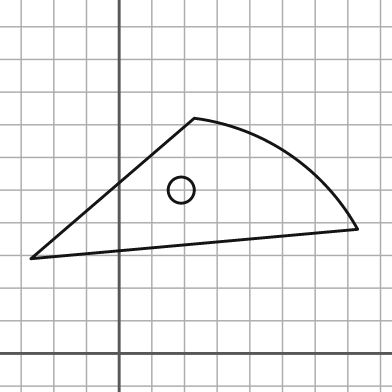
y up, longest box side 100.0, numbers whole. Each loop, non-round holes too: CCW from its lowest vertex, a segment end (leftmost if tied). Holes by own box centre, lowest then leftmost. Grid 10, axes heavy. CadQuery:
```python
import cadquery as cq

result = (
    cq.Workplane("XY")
    .moveTo(-27.0, 29.0)
    .lineTo(73.0, 38.0)
    .threePointArc((52.0, 61.0), (23.0, 72.0))
    .close()
    .moveTo(19.0, 50.0)
    .circle(4.0)
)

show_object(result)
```